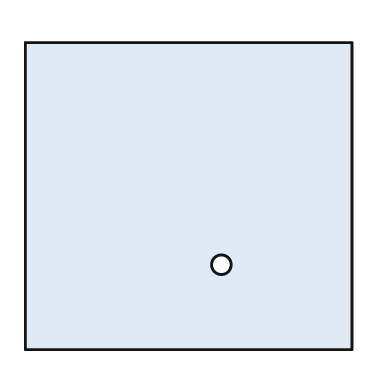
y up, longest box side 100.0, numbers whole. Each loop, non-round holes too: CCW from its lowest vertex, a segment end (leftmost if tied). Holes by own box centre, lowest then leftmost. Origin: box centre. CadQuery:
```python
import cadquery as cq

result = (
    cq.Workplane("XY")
    .moveTo(-50.0, -47.0)
    .lineTo(50.0, -47.0)
    .lineTo(50.0, 47.0)
    .lineTo(-50.0, 47.0)
    .close()
    .moveTo(10.0, -21.0)
    .circle(3.0)
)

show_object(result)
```